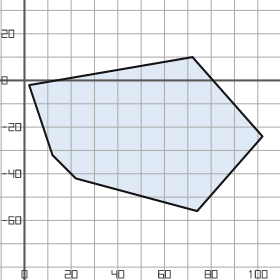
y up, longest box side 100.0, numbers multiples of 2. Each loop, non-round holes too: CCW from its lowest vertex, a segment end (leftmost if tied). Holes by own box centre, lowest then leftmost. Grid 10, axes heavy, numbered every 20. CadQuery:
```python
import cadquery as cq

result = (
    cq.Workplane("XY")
    .moveTo(74.0, -56.0)
    .lineTo(102.0, -24.0)
    .lineTo(72.0, 10.0)
    .lineTo(2.0, -2.0)
    .lineTo(12.0, -32.0)
    .lineTo(22.0, -42.0)
    .close()
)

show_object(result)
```